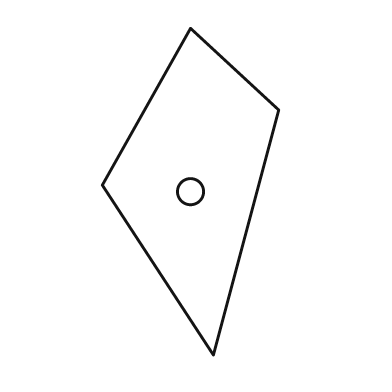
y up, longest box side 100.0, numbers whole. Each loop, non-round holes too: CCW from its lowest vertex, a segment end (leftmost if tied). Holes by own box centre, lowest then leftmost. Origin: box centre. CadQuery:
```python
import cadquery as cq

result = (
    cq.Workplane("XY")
    .moveTo(7.0, -50.0)
    .lineTo(27.0, 25.0)
    .lineTo(0.0, 50.0)
    .lineTo(-27.0, 2.0)
    .close()
    .moveTo(0.0, 0.0)
    .circle(4.0)
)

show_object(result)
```